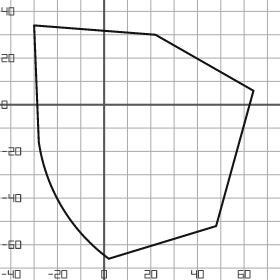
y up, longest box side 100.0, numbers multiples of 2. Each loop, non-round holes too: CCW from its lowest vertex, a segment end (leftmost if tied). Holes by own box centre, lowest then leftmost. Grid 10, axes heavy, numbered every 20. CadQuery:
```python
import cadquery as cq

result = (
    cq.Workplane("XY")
    .moveTo(2.0, -66.0)
    .lineTo(48.0, -52.0)
    .lineTo(64.0, 6.0)
    .lineTo(22.0, 30.0)
    .lineTo(-30.0, 34.0)
    .lineTo(-28.0, -16.0)
    .threePointArc((-18.0, -44.0), (2.0, -66.0))
    .close()
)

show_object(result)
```